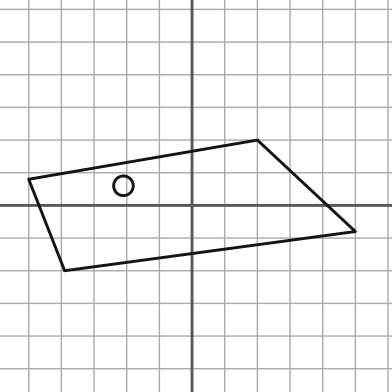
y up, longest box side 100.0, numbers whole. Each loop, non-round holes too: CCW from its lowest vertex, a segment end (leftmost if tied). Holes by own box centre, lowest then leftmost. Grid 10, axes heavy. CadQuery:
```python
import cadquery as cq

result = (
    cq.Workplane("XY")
    .moveTo(-39.0, -20.0)
    .lineTo(50.0, -8.0)
    .lineTo(20.0, 20.0)
    .lineTo(-50.0, 8.0)
    .close()
    .moveTo(-21.0, 6.0)
    .circle(3.0)
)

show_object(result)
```